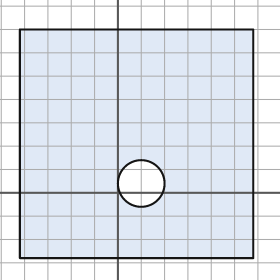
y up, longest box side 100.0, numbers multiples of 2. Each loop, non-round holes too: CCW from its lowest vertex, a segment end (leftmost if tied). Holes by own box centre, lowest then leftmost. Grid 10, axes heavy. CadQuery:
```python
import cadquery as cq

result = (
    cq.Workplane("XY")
    .moveTo(-42.0, -28.0)
    .lineTo(58.0, -28.0)
    .lineTo(58.0, 70.0)
    .lineTo(-42.0, 70.0)
    .close()
    .moveTo(10.0, 4.0)
    .circle(10.0)
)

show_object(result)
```